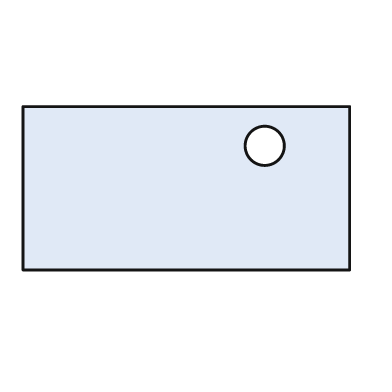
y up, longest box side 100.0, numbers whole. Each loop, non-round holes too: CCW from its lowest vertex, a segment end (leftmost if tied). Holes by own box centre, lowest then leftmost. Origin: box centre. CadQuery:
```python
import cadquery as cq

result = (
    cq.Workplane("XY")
    .moveTo(-50.0, -25.0)
    .lineTo(50.0, -25.0)
    .lineTo(50.0, 25.0)
    .lineTo(-50.0, 25.0)
    .close()
    .moveTo(24.0, 13.0)
    .circle(6.0)
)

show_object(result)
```